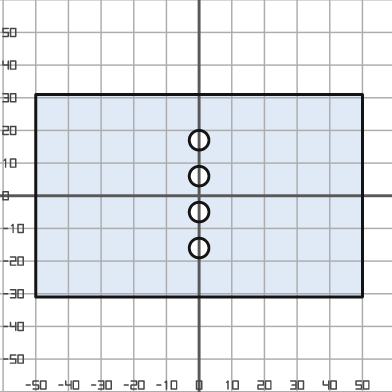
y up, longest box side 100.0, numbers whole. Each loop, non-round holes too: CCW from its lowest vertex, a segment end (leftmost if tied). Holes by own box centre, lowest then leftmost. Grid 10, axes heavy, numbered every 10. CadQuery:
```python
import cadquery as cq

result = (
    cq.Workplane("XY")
    .moveTo(-50.0, -31.0)
    .lineTo(50.0, -31.0)
    .lineTo(50.0, 31.0)
    .lineTo(-50.0, 31.0)
    .close()
    .moveTo(0.0, -16.0)
    .circle(3.0)
    .moveTo(0.0, -5.0)
    .circle(3.0)
    .moveTo(0.0, 6.0)
    .circle(3.0)
    .moveTo(0.0, 17.0)
    .circle(3.0)
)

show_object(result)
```